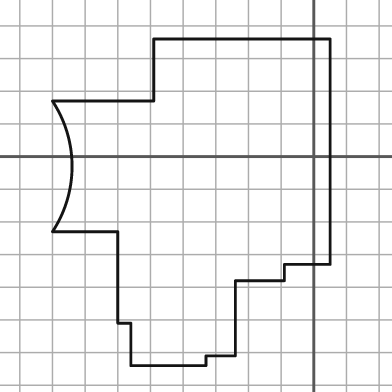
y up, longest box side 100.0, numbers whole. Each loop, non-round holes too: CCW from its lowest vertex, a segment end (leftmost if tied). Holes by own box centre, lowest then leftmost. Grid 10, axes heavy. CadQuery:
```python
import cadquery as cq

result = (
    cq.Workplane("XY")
    .moveTo(-56.0, -64.0)
    .lineTo(-33.0, -64.0)
    .lineTo(-33.0, -61.0)
    .lineTo(-24.0, -61.0)
    .lineTo(-24.0, -38.0)
    .lineTo(-9.0, -38.0)
    .lineTo(-9.0, -33.0)
    .lineTo(5.0, -33.0)
    .lineTo(5.0, 36.0)
    .lineTo(-49.0, 36.0)
    .lineTo(-49.0, 17.0)
    .lineTo(-80.0, 17.0)
    .threePointArc((-74.0, -3.0), (-80.0, -23.0))
    .lineTo(-60.0, -23.0)
    .lineTo(-60.0, -51.0)
    .lineTo(-56.0, -51.0)
    .close()
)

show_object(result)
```